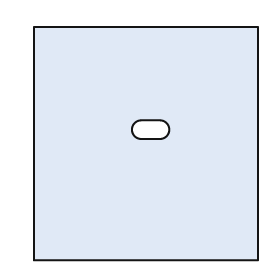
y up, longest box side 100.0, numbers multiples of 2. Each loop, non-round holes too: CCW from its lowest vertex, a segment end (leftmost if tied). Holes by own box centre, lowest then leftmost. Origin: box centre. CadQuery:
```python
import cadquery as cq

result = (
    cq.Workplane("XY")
    .moveTo(-48.0, -50.0)
    .lineTo(48.0, -50.0)
    .lineTo(48.0, 50.0)
    .lineTo(-48.0, 50.0)
    .close()
    .moveTo(-2.0, 2.0)
    .lineTo(6.0, 2.0)
    .threePointArc((10.0, 6.0), (6.0, 10.0))
    .lineTo(-2.0, 10.0)
    .threePointArc((-6.0, 6.0), (-2.0, 2.0))
    .close()
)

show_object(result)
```